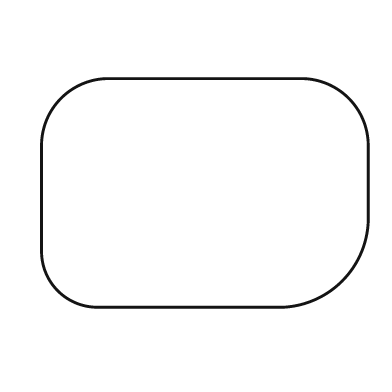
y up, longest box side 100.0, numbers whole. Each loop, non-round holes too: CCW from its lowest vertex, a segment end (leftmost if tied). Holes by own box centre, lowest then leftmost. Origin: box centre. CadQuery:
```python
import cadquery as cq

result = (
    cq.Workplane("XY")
    .moveTo(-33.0, -35.0)
    .lineTo(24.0, -35.0)
    .threePointArc((42.0, -27.0), (50.0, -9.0))
    .lineTo(50.0, 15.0)
    .threePointArc((44.0, 29.0), (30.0, 35.0))
    .lineTo(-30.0, 35.0)
    .threePointArc((-44.0, 29.0), (-50.0, 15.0))
    .lineTo(-50.0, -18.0)
    .threePointArc((-45.0, -30.0), (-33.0, -35.0))
    .close()
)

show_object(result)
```